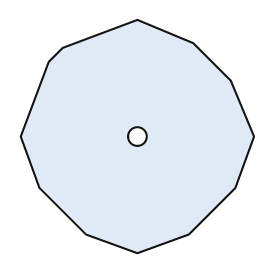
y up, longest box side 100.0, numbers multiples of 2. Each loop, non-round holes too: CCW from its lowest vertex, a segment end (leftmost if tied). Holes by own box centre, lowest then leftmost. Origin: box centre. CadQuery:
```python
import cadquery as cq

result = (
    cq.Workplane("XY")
    .moveTo(0.0, -50.0)
    .lineTo(22.0, -42.0)
    .lineTo(42.0, -22.0)
    .lineTo(50.0, 0.0)
    .lineTo(40.0, 24.0)
    .lineTo(24.0, 40.0)
    .lineTo(0.0, 50.0)
    .lineTo(-32.0, 38.0)
    .lineTo(-38.0, 32.0)
    .lineTo(-50.0, 0.0)
    .lineTo(-42.0, -22.0)
    .lineTo(-22.0, -42.0)
    .close()
    .moveTo(0.0, 0.0)
    .circle(4.0)
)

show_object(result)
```